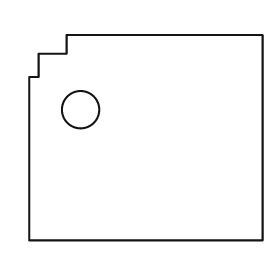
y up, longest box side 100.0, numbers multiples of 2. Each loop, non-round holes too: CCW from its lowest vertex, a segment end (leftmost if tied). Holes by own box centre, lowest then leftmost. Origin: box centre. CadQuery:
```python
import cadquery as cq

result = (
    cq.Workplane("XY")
    .moveTo(-50.0, -44.0)
    .lineTo(50.0, -44.0)
    .lineTo(50.0, 44.0)
    .lineTo(-34.0, 44.0)
    .lineTo(-34.0, 36.0)
    .lineTo(-46.0, 36.0)
    .lineTo(-46.0, 26.0)
    .lineTo(-50.0, 26.0)
    .close()
    .moveTo(-28.0, 12.0)
    .circle(8.0)
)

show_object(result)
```